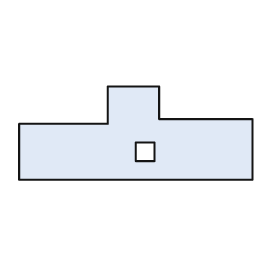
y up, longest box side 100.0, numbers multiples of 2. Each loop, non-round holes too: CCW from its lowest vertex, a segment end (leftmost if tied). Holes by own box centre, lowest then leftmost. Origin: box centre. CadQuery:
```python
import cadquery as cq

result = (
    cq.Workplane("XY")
    .moveTo(-50.0, -20.0)
    .lineTo(50.0, -20.0)
    .lineTo(50.0, 6.0)
    .lineTo(10.0, 6.0)
    .lineTo(10.0, 20.0)
    .lineTo(-12.0, 20.0)
    .lineTo(-12.0, 4.0)
    .lineTo(-50.0, 4.0)
    .close()
    .moveTo(0.0, -12.0)
    .lineTo(8.0, -12.0)
    .lineTo(8.0, -4.0)
    .lineTo(0.0, -4.0)
    .close()
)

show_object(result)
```